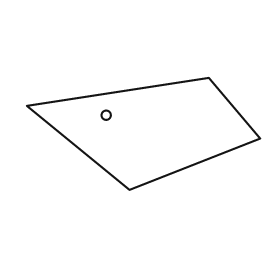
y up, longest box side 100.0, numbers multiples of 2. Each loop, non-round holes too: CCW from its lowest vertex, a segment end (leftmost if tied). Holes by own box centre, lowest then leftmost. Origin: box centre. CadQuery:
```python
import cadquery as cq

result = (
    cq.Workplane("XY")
    .moveTo(-6.0, -24.0)
    .lineTo(50.0, -2.0)
    .lineTo(28.0, 24.0)
    .lineTo(-50.0, 12.0)
    .close()
    .moveTo(-16.0, 8.0)
    .circle(2.0)
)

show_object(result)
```